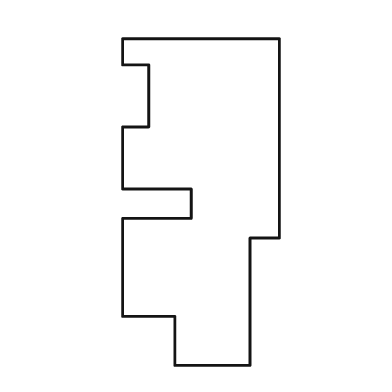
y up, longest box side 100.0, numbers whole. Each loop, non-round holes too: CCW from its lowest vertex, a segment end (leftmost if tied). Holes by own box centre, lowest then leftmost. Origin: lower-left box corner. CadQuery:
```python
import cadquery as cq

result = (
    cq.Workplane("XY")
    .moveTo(16.0, 0.0)
    .lineTo(39.0, 0.0)
    .lineTo(39.0, 39.0)
    .lineTo(48.0, 39.0)
    .lineTo(48.0, 100.0)
    .lineTo(0.0, 100.0)
    .lineTo(0.0, 92.0)
    .lineTo(8.0, 92.0)
    .lineTo(8.0, 73.0)
    .lineTo(0.0, 73.0)
    .lineTo(0.0, 54.0)
    .lineTo(21.0, 54.0)
    .lineTo(21.0, 45.0)
    .lineTo(0.0, 45.0)
    .lineTo(0.0, 15.0)
    .lineTo(16.0, 15.0)
    .close()
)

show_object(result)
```